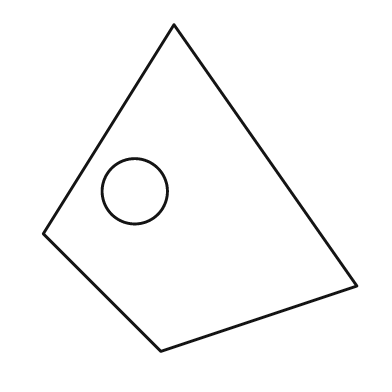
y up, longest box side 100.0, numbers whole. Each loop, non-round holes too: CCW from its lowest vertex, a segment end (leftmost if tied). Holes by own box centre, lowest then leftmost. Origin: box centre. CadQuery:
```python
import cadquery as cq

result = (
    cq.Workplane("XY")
    .moveTo(-12.0, -50.0)
    .lineTo(48.0, -30.0)
    .lineTo(-8.0, 50.0)
    .lineTo(-48.0, -14.0)
    .close()
    .moveTo(-20.0, -1.0)
    .circle(10.0)
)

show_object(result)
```